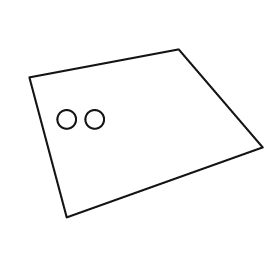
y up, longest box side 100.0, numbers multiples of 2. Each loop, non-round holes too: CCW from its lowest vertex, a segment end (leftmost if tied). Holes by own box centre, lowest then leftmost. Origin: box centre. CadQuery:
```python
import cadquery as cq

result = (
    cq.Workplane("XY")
    .moveTo(-34.0, -36.0)
    .lineTo(50.0, -6.0)
    .lineTo(14.0, 36.0)
    .lineTo(-50.0, 24.0)
    .close()
    .moveTo(-34.0, 6.0)
    .circle(4.0)
    .moveTo(-22.0, 6.0)
    .circle(4.0)
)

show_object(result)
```